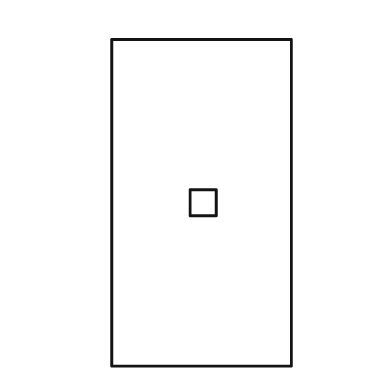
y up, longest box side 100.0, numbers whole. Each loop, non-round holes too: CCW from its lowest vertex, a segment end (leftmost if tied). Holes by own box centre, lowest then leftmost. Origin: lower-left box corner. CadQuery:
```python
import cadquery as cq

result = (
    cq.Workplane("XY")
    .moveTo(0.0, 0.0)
    .lineTo(55.0, 0.0)
    .lineTo(55.0, 100.0)
    .lineTo(0.0, 100.0)
    .close()
    .moveTo(24.0, 46.0)
    .lineTo(32.0, 46.0)
    .lineTo(32.0, 54.0)
    .lineTo(24.0, 54.0)
    .close()
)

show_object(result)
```